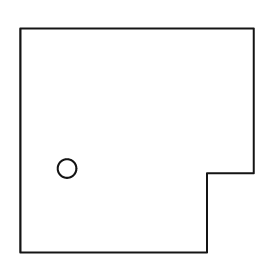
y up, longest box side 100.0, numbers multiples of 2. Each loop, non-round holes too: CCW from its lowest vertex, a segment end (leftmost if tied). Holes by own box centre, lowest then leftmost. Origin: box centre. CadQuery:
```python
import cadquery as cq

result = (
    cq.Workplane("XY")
    .moveTo(-50.0, -48.0)
    .lineTo(30.0, -48.0)
    .lineTo(30.0, -14.0)
    .lineTo(50.0, -14.0)
    .lineTo(50.0, 48.0)
    .lineTo(-50.0, 48.0)
    .close()
    .moveTo(-30.0, -12.0)
    .circle(4.0)
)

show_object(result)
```